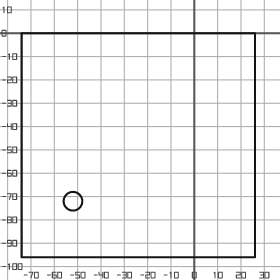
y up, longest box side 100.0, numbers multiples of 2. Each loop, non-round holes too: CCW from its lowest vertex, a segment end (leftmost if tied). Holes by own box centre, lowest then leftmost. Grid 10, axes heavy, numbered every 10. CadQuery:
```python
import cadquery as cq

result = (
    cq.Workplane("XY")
    .moveTo(-74.0, -96.0)
    .lineTo(26.0, -96.0)
    .lineTo(26.0, 0.0)
    .lineTo(-74.0, 0.0)
    .close()
    .moveTo(-52.0, -72.0)
    .circle(4.0)
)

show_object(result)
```